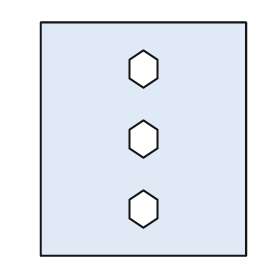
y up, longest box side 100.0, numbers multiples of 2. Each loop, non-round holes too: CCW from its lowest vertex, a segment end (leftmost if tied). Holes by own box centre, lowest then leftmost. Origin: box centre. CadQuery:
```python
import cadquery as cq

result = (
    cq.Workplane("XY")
    .moveTo(-44.0, -50.0)
    .lineTo(44.0, -50.0)
    .lineTo(44.0, 50.0)
    .lineTo(-44.0, 50.0)
    .close()
    .moveTo(0.0, -38.0)
    .lineTo(6.0, -34.0)
    .lineTo(6.0, -26.0)
    .lineTo(0.0, -22.0)
    .lineTo(-6.0, -26.0)
    .lineTo(-6.0, -34.0)
    .close()
    .moveTo(0.0, -8.0)
    .lineTo(6.0, -4.0)
    .lineTo(6.0, 4.0)
    .lineTo(0.0, 8.0)
    .lineTo(-6.0, 4.0)
    .lineTo(-6.0, -4.0)
    .close()
    .moveTo(0.0, 22.0)
    .lineTo(6.0, 26.0)
    .lineTo(6.0, 34.0)
    .lineTo(0.0, 38.0)
    .lineTo(-6.0, 34.0)
    .lineTo(-6.0, 26.0)
    .close()
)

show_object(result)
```